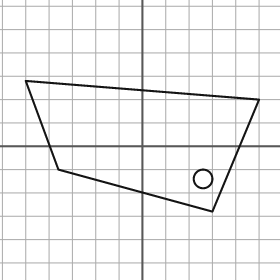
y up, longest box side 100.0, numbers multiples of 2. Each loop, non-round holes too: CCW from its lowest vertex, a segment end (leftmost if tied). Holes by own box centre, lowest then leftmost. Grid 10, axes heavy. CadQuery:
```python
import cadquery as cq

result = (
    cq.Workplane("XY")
    .moveTo(30.0, -28.0)
    .lineTo(50.0, 20.0)
    .lineTo(-50.0, 28.0)
    .lineTo(-36.0, -10.0)
    .close()
    .moveTo(26.0, -14.0)
    .circle(4.0)
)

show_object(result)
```